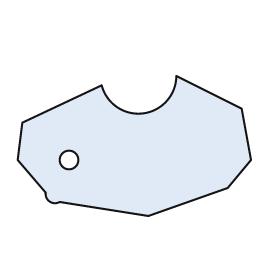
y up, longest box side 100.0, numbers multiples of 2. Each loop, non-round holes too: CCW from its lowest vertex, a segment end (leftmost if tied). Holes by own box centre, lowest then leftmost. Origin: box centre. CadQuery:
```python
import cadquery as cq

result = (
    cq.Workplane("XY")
    .moveTo(6.0, -30.0)
    .lineTo(40.0, -18.0)
    .lineTo(50.0, -6.0)
    .lineTo(46.0, 16.0)
    .lineTo(18.0, 30.0)
    .threePointArc((4.0, 14.0), (-14.0, 26.0))
    .lineTo(-48.0, 10.0)
    .lineTo(-50.0, -6.0)
    .lineTo(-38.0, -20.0)
    .threePointArc((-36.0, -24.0), (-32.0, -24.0))
    .close()
    .moveTo(-28.0, -6.0)
    .circle(4.0)
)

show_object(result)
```